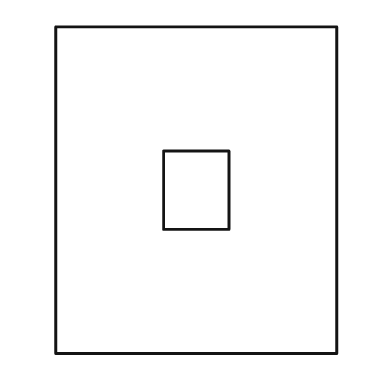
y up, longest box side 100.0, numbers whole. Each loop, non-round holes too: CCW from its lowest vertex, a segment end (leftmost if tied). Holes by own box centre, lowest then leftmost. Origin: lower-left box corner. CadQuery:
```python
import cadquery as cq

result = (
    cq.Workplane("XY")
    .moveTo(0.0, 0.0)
    .lineTo(86.0, 0.0)
    .lineTo(86.0, 100.0)
    .lineTo(0.0, 100.0)
    .close()
    .moveTo(33.0, 38.0)
    .lineTo(53.0, 38.0)
    .lineTo(53.0, 62.0)
    .lineTo(33.0, 62.0)
    .close()
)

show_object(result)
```